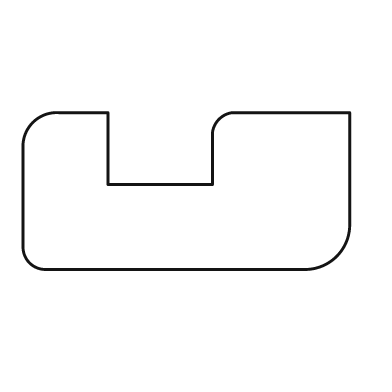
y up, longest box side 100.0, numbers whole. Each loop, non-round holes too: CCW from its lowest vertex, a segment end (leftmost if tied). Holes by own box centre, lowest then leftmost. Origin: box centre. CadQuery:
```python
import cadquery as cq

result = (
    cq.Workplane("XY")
    .moveTo(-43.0, -24.0)
    .lineTo(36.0, -24.0)
    .threePointArc((46.0, -20.0), (50.0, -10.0))
    .lineTo(50.0, 24.0)
    .lineTo(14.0, 24.0)
    .threePointArc((10.0, 22.0), (8.0, 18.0))
    .lineTo(8.0, 2.0)
    .lineTo(-24.0, 2.0)
    .lineTo(-24.0, 24.0)
    .lineTo(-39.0, 24.0)
    .threePointArc((-47.0, 21.0), (-50.0, 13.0))
    .lineTo(-50.0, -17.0)
    .threePointArc((-48.0, -22.0), (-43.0, -24.0))
    .close()
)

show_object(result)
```